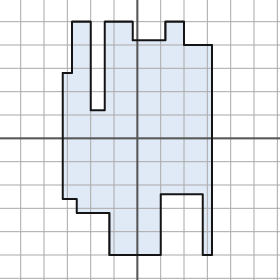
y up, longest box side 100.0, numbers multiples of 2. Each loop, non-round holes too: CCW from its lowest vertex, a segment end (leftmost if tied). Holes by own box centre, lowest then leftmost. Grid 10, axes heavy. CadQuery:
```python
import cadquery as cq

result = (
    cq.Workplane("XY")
    .moveTo(-12.0, -50.0)
    .lineTo(10.0, -50.0)
    .lineTo(10.0, -24.0)
    .lineTo(28.0, -24.0)
    .lineTo(28.0, -50.0)
    .lineTo(32.0, -50.0)
    .lineTo(32.0, 40.0)
    .lineTo(20.0, 40.0)
    .lineTo(20.0, 50.0)
    .lineTo(12.0, 50.0)
    .lineTo(12.0, 42.0)
    .lineTo(-2.0, 42.0)
    .lineTo(-2.0, 50.0)
    .lineTo(-14.0, 50.0)
    .lineTo(-14.0, 12.0)
    .lineTo(-20.0, 12.0)
    .lineTo(-20.0, 50.0)
    .lineTo(-28.0, 50.0)
    .lineTo(-28.0, 28.0)
    .lineTo(-32.0, 28.0)
    .lineTo(-32.0, -26.0)
    .lineTo(-26.0, -26.0)
    .lineTo(-26.0, -32.0)
    .lineTo(-12.0, -32.0)
    .close()
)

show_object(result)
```